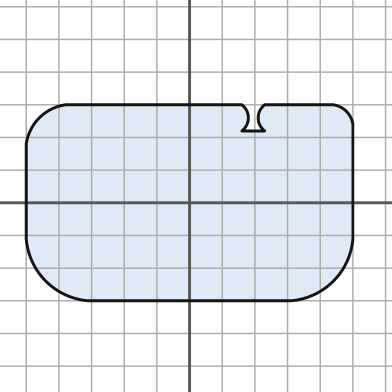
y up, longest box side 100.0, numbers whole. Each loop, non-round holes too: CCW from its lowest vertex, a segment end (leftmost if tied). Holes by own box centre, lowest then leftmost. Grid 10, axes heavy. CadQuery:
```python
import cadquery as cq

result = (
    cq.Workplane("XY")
    .moveTo(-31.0, -30.0)
    .lineTo(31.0, -30.0)
    .threePointArc((44.0, -24.0), (50.0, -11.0))
    .lineTo(50.0, 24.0)
    .threePointArc((48.0, 28.0), (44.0, 30.0))
    .lineTo(23.0, 30.0)
    .threePointArc((21.0, 26.0), (23.0, 22.0))
    .lineTo(16.0, 22.0)
    .threePointArc((18.0, 26.0), (16.0, 30.0))
    .lineTo(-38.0, 30.0)
    .threePointArc((-46.0, 26.0), (-50.0, 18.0))
    .lineTo(-50.0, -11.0)
    .threePointArc((-44.0, -24.0), (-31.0, -30.0))
    .close()
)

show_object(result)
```